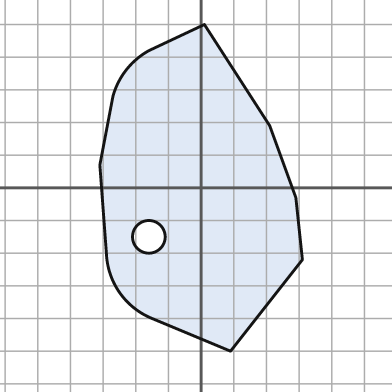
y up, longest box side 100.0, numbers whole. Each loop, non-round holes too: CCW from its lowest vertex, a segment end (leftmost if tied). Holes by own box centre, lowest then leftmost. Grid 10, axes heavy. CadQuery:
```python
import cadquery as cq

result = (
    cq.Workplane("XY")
    .moveTo(9.0, -50.0)
    .lineTo(31.0, -22.0)
    .lineTo(29.0, -3.0)
    .lineTo(21.0, 19.0)
    .lineTo(1.0, 50.0)
    .lineTo(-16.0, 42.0)
    .threePointArc((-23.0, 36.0), (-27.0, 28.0))
    .lineTo(-31.0, 7.0)
    .lineTo(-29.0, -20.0)
    .threePointArc((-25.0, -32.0), (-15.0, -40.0))
    .close()
    .moveTo(-16.0, -15.0)
    .circle(5.0)
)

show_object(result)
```